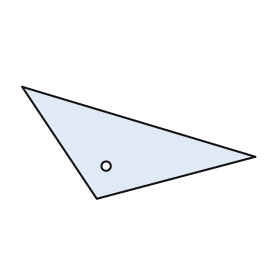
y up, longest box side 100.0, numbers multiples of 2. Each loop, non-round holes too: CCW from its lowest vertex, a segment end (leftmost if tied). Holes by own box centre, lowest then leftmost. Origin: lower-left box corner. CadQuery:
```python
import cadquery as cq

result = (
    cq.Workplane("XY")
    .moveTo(32.0, 0.0)
    .lineTo(100.0, 18.0)
    .lineTo(0.0, 48.0)
    .close()
    .moveTo(36.0, 14.0)
    .circle(2.0)
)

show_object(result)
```